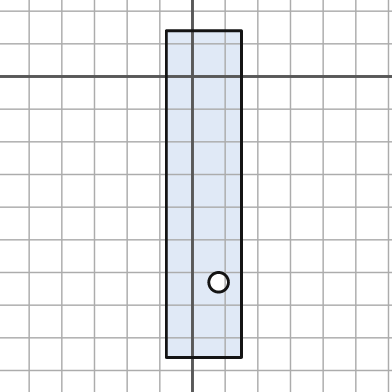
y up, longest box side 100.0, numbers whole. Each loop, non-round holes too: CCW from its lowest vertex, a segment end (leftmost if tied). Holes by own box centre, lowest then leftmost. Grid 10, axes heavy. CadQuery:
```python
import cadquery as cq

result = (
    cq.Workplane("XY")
    .moveTo(-8.0, -86.0)
    .lineTo(15.0, -86.0)
    .lineTo(15.0, 14.0)
    .lineTo(-8.0, 14.0)
    .close()
    .moveTo(8.0, -63.0)
    .circle(3.0)
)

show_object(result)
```